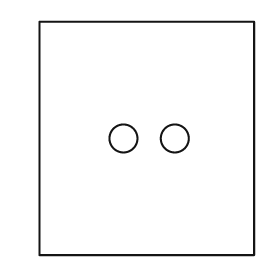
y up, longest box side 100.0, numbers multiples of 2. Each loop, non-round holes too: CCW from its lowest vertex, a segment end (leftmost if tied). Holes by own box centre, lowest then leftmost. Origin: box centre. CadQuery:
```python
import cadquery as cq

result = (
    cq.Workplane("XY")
    .moveTo(-46.0, -50.0)
    .lineTo(46.0, -50.0)
    .lineTo(46.0, 50.0)
    .lineTo(-46.0, 50.0)
    .close()
    .moveTo(-10.0, 0.0)
    .circle(6.0)
    .moveTo(12.0, 0.0)
    .circle(6.0)
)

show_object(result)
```